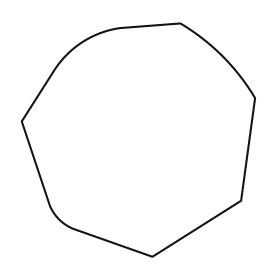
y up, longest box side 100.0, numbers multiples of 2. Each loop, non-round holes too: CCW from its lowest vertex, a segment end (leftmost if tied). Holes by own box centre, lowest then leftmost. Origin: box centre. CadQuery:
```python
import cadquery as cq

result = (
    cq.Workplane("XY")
    .moveTo(6.0, -50.0)
    .lineTo(44.0, -26.0)
    .lineTo(50.0, 18.0)
    .threePointArc((36.0, 36.0), (18.0, 50.0))
    .lineTo(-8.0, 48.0)
    .threePointArc((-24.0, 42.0), (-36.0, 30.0))
    .lineTo(-50.0, 8.0)
    .lineTo(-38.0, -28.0)
    .threePointArc((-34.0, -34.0), (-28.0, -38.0))
    .close()
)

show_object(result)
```